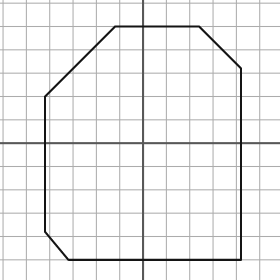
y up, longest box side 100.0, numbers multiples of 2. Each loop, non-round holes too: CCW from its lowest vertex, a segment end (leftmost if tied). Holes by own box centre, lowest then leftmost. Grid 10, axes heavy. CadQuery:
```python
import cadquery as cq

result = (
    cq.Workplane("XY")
    .moveTo(-32.0, -50.0)
    .lineTo(42.0, -50.0)
    .lineTo(42.0, 32.0)
    .lineTo(24.0, 50.0)
    .lineTo(-12.0, 50.0)
    .lineTo(-42.0, 20.0)
    .lineTo(-42.0, -38.0)
    .close()
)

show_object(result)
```